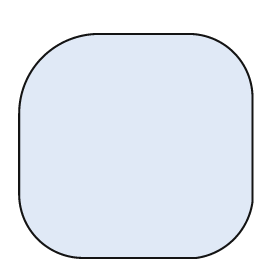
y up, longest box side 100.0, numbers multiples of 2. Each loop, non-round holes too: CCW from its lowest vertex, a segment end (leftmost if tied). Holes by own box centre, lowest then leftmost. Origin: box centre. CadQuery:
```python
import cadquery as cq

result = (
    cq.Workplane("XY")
    .moveTo(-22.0, -48.0)
    .lineTo(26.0, -48.0)
    .threePointArc((42.0, -40.0), (50.0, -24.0))
    .lineTo(50.0, 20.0)
    .threePointArc((42.0, 40.0), (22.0, 48.0))
    .lineTo(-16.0, 48.0)
    .threePointArc((-40.0, 38.0), (-50.0, 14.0))
    .lineTo(-50.0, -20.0)
    .threePointArc((-42.0, -40.0), (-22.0, -48.0))
    .close()
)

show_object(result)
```